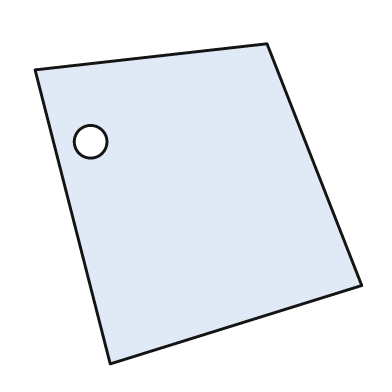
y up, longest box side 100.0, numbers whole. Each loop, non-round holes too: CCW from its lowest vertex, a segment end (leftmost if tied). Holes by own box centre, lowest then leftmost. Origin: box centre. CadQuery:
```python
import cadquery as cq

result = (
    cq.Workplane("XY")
    .moveTo(-27.0, -49.0)
    .lineTo(50.0, -25.0)
    .lineTo(21.0, 49.0)
    .lineTo(-50.0, 41.0)
    .close()
    .moveTo(-33.0, 19.0)
    .circle(5.0)
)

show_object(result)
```